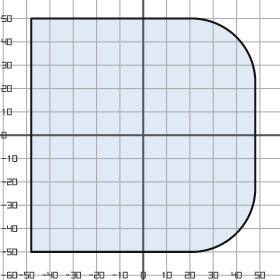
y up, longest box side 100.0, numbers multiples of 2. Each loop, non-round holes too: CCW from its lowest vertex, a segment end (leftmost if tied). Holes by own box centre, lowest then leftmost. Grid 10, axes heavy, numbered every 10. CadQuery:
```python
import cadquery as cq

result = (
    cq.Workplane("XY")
    .moveTo(-48.0, -50.0)
    .lineTo(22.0, -50.0)
    .threePointArc((40.0, -42.0), (48.0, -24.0))
    .lineTo(48.0, 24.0)
    .threePointArc((40.0, 42.0), (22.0, 50.0))
    .lineTo(-48.0, 50.0)
    .close()
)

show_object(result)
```